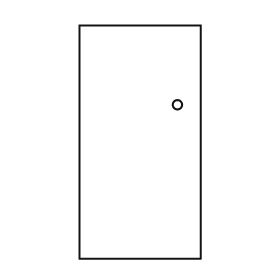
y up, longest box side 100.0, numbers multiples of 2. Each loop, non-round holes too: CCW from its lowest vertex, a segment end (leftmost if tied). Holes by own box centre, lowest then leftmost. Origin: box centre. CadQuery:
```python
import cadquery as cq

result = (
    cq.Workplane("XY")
    .moveTo(-26.0, -50.0)
    .lineTo(26.0, -50.0)
    .lineTo(26.0, 50.0)
    .lineTo(-26.0, 50.0)
    .close()
    .moveTo(16.0, 16.0)
    .circle(2.0)
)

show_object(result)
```